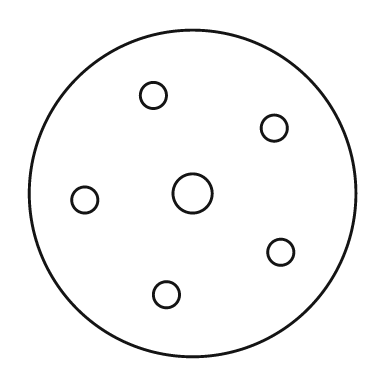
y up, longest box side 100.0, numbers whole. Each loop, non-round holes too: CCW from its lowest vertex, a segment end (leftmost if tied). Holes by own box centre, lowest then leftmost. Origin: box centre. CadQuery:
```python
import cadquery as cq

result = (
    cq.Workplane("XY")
    .moveTo(0.0, 0.0)
    .circle(50.0)
    .moveTo(-8.0, -31.0)
    .circle(4.0)
    .moveTo(27.0, -18.0)
    .circle(4.0)
    .moveTo(-33.0, -2.0)
    .circle(4.0)
    .moveTo(0.0, 0.0)
    .circle(6.0)
    .moveTo(25.0, 20.0)
    .circle(4.0)
    .moveTo(-12.0, 30.0)
    .circle(4.0)
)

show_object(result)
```